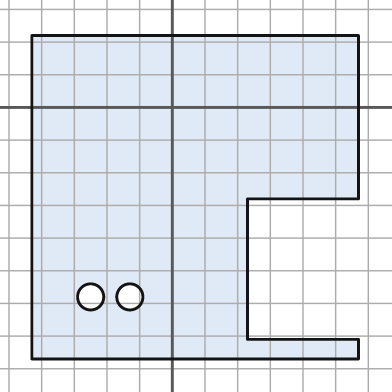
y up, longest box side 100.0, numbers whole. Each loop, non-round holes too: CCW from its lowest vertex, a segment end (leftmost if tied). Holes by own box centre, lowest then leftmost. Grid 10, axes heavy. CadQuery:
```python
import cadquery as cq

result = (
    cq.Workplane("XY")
    .moveTo(-43.0, -77.0)
    .lineTo(57.0, -77.0)
    .lineTo(57.0, -71.0)
    .lineTo(23.0, -71.0)
    .lineTo(23.0, -28.0)
    .lineTo(57.0, -28.0)
    .lineTo(57.0, 22.0)
    .lineTo(-43.0, 22.0)
    .close()
    .moveTo(-25.0, -58.0)
    .circle(4.0)
    .moveTo(-13.0, -58.0)
    .circle(4.0)
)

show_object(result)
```